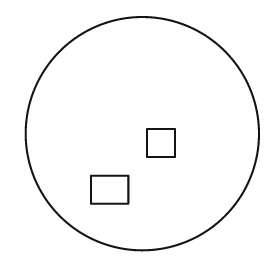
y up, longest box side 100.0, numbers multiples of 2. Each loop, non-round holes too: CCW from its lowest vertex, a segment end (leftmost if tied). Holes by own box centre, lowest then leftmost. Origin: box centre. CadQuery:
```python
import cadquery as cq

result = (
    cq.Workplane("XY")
    .moveTo(0.0, 0.0)
    .circle(50.0)
    .moveTo(-22.0, -30.0)
    .lineTo(-6.0, -30.0)
    .lineTo(-6.0, -18.0)
    .lineTo(-22.0, -18.0)
    .close()
    .moveTo(2.0, -10.0)
    .lineTo(14.0, -10.0)
    .lineTo(14.0, 2.0)
    .lineTo(2.0, 2.0)
    .close()
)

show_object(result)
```